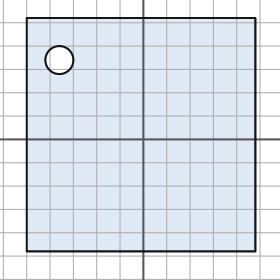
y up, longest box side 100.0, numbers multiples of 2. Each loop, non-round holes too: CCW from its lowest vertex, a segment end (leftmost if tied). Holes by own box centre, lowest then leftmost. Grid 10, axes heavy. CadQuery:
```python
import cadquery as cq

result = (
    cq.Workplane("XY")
    .moveTo(-50.0, -48.0)
    .lineTo(48.0, -48.0)
    .lineTo(48.0, 52.0)
    .lineTo(-50.0, 52.0)
    .close()
    .moveTo(-36.0, 34.0)
    .circle(6.0)
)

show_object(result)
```